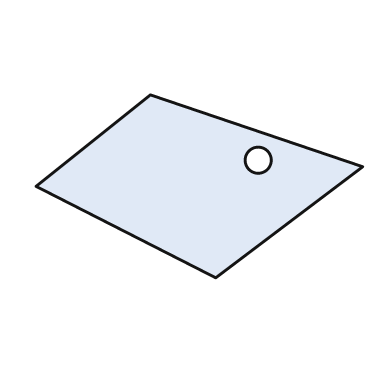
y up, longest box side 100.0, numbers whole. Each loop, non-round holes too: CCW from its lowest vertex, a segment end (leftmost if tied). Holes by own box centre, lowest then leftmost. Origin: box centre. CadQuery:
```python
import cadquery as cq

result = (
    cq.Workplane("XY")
    .moveTo(5.0, -28.0)
    .lineTo(50.0, 6.0)
    .lineTo(-15.0, 28.0)
    .lineTo(-50.0, 0.0)
    .close()
    .moveTo(18.0, 8.0)
    .circle(4.0)
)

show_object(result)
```